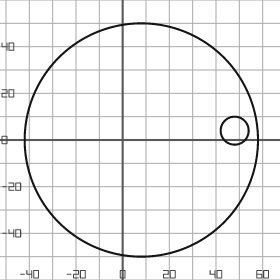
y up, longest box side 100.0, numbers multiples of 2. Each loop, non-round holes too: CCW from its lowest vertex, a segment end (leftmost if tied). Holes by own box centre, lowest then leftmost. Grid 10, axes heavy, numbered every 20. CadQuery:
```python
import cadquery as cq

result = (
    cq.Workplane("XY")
    .moveTo(8.0, 0.0)
    .circle(50.0)
    .moveTo(48.0, 4.0)
    .circle(6.0)
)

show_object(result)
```